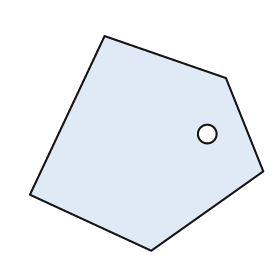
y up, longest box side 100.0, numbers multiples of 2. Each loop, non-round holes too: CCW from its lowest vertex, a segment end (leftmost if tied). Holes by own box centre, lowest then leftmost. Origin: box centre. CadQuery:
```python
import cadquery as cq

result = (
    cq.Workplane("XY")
    .moveTo(2.0, -46.0)
    .lineTo(50.0, -12.0)
    .lineTo(34.0, 28.0)
    .lineTo(-18.0, 46.0)
    .lineTo(-50.0, -22.0)
    .close()
    .moveTo(26.0, 4.0)
    .circle(4.0)
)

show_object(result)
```